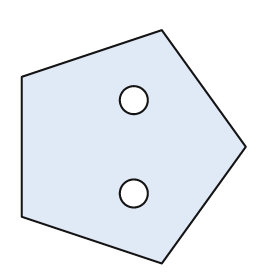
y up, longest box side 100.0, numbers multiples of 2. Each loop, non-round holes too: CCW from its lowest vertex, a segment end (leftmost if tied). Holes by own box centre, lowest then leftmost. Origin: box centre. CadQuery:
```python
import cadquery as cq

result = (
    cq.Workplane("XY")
    .moveTo(12.0, -50.0)
    .lineTo(48.0, 0.0)
    .lineTo(12.0, 50.0)
    .lineTo(-48.0, 30.0)
    .lineTo(-48.0, -30.0)
    .close()
    .moveTo(0.0, -20.0)
    .circle(6.0)
    .moveTo(0.0, 20.0)
    .circle(6.0)
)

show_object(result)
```